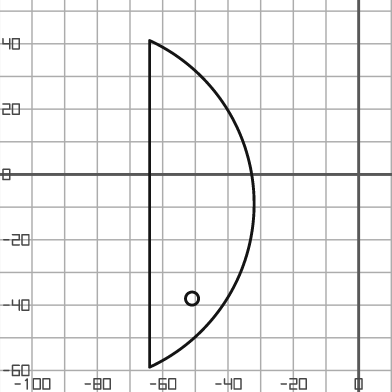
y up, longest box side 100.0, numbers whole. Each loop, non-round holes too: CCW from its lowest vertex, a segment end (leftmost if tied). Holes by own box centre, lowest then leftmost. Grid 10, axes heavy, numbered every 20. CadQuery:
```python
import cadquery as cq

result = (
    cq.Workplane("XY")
    .moveTo(-64.0, -59.0)
    .threePointArc((-32.0, -9.0), (-64.0, 41.0))
    .close()
    .moveTo(-51.0, -38.0)
    .circle(2.0)
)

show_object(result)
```